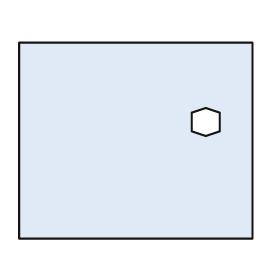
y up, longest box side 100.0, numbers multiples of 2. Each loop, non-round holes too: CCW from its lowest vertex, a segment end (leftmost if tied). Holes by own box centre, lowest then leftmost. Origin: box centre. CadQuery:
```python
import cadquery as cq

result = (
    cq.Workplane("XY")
    .moveTo(-50.0, -42.0)
    .lineTo(50.0, -42.0)
    .lineTo(50.0, 42.0)
    .lineTo(-50.0, 42.0)
    .close()
    .moveTo(30.0, 2.0)
    .lineTo(36.0, 4.0)
    .lineTo(36.0, 12.0)
    .lineTo(30.0, 14.0)
    .lineTo(24.0, 12.0)
    .lineTo(24.0, 4.0)
    .close()
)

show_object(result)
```